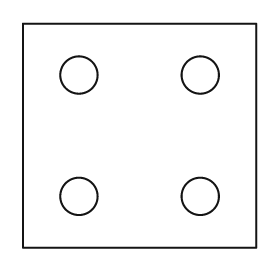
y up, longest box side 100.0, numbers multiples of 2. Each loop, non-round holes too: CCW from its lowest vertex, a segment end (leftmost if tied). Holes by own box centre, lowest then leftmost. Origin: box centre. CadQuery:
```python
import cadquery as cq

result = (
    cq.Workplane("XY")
    .moveTo(-50.0, -48.0)
    .lineTo(50.0, -48.0)
    .lineTo(50.0, 48.0)
    .lineTo(-50.0, 48.0)
    .close()
    .moveTo(-26.0, -26.0)
    .circle(8.0)
    .moveTo(26.0, -26.0)
    .circle(8.0)
    .moveTo(-26.0, 26.0)
    .circle(8.0)
    .moveTo(26.0, 26.0)
    .circle(8.0)
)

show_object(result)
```